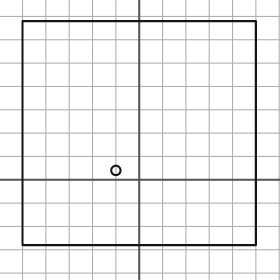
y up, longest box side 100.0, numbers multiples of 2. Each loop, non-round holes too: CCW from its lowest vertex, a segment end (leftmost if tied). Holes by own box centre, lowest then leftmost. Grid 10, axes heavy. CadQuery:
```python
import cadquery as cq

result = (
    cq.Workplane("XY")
    .moveTo(-50.0, -28.0)
    .lineTo(50.0, -28.0)
    .lineTo(50.0, 68.0)
    .lineTo(-50.0, 68.0)
    .close()
    .moveTo(-10.0, 4.0)
    .circle(2.0)
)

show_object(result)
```